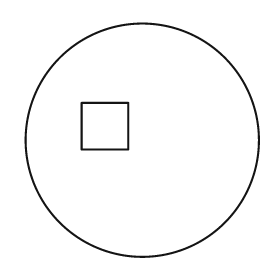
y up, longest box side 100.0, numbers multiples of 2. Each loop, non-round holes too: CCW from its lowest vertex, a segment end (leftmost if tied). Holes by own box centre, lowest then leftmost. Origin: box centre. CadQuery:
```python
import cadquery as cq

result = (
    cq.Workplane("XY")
    .moveTo(0.0, 0.0)
    .circle(50.0)
    .moveTo(-26.0, -4.0)
    .lineTo(-6.0, -4.0)
    .lineTo(-6.0, 16.0)
    .lineTo(-26.0, 16.0)
    .close()
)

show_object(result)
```